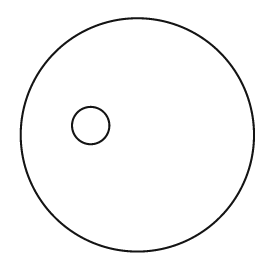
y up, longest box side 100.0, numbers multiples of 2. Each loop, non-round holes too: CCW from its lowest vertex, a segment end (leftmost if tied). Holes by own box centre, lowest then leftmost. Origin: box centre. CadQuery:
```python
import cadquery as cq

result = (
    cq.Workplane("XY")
    .moveTo(0.0, 0.0)
    .circle(50.0)
    .moveTo(-20.0, 4.0)
    .circle(8.0)
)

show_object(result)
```